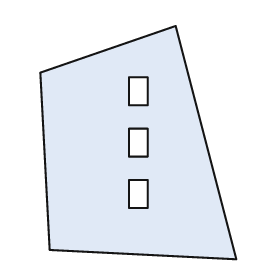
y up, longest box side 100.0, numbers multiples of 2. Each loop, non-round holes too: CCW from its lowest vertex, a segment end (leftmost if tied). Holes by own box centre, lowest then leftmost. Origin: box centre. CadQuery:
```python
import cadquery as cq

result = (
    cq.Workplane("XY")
    .moveTo(42.0, -50.0)
    .lineTo(16.0, 50.0)
    .lineTo(-42.0, 30.0)
    .lineTo(-38.0, -46.0)
    .close()
    .moveTo(-4.0, -28.0)
    .lineTo(4.0, -28.0)
    .lineTo(4.0, -16.0)
    .lineTo(-4.0, -16.0)
    .close()
    .moveTo(-4.0, -6.0)
    .lineTo(4.0, -6.0)
    .lineTo(4.0, 6.0)
    .lineTo(-4.0, 6.0)
    .close()
    .moveTo(-4.0, 16.0)
    .lineTo(4.0, 16.0)
    .lineTo(4.0, 28.0)
    .lineTo(-4.0, 28.0)
    .close()
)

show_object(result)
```